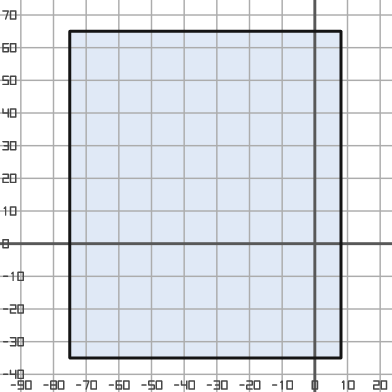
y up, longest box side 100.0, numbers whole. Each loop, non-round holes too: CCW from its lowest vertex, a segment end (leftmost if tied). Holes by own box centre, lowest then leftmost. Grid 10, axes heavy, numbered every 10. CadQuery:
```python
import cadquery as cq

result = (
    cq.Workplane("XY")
    .moveTo(-75.0, -35.0)
    .lineTo(8.0, -35.0)
    .lineTo(8.0, 65.0)
    .lineTo(-75.0, 65.0)
    .close()
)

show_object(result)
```